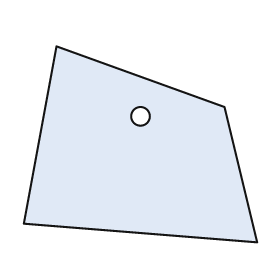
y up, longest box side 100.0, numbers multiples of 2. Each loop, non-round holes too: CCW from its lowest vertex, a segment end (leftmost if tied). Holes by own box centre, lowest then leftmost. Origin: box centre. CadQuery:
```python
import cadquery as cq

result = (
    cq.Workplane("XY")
    .moveTo(50.0, -42.0)
    .lineTo(36.0, 16.0)
    .lineTo(-36.0, 42.0)
    .lineTo(-50.0, -34.0)
    .close()
    .moveTo(0.0, 12.0)
    .circle(4.0)
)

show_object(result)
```